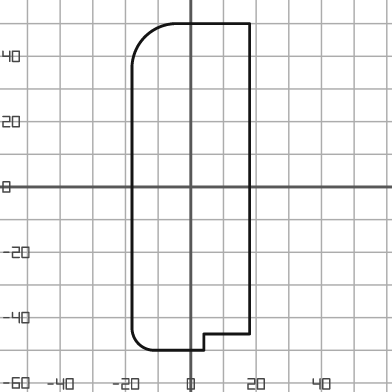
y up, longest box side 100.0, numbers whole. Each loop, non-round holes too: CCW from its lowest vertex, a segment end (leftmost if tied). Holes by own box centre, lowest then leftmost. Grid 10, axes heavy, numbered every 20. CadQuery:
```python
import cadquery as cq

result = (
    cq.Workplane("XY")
    .moveTo(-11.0, -50.0)
    .lineTo(4.0, -50.0)
    .lineTo(4.0, -45.0)
    .lineTo(18.0, -45.0)
    .lineTo(18.0, 50.0)
    .lineTo(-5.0, 50.0)
    .threePointArc((-14.0, 46.0), (-18.0, 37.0))
    .lineTo(-18.0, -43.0)
    .threePointArc((-16.0, -48.0), (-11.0, -50.0))
    .close()
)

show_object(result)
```